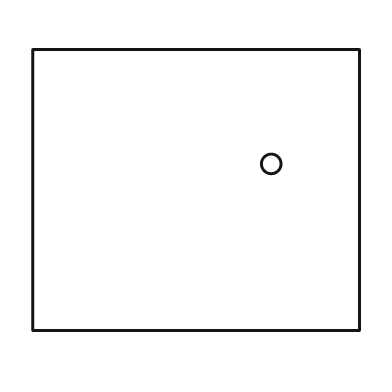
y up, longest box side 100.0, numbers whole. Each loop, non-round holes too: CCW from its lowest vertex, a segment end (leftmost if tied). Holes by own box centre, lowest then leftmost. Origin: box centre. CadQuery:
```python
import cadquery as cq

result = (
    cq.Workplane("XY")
    .moveTo(-50.0, -43.0)
    .lineTo(50.0, -43.0)
    .lineTo(50.0, 43.0)
    .lineTo(-50.0, 43.0)
    .close()
    .moveTo(23.0, 8.0)
    .circle(3.0)
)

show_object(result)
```